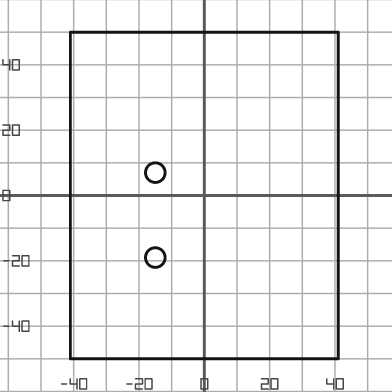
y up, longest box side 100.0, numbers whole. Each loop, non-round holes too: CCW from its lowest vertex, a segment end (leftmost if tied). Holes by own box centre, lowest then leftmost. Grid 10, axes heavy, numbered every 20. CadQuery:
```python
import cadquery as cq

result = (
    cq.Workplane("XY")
    .moveTo(-41.0, -50.0)
    .lineTo(41.0, -50.0)
    .lineTo(41.0, 50.0)
    .lineTo(-41.0, 50.0)
    .close()
    .moveTo(-15.0, -19.0)
    .circle(3.0)
    .moveTo(-15.0, 7.0)
    .circle(3.0)
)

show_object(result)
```